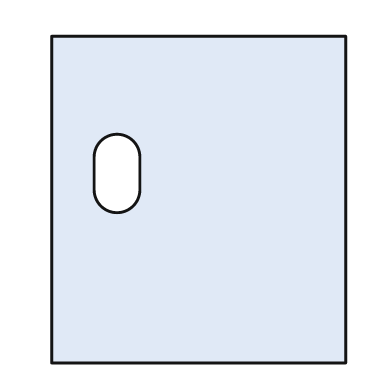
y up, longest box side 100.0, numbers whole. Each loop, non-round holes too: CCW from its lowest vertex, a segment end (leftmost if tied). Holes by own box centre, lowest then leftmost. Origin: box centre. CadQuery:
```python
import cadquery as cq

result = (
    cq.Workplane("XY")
    .moveTo(-45.0, -50.0)
    .lineTo(45.0, -50.0)
    .lineTo(45.0, 50.0)
    .lineTo(-45.0, 50.0)
    .close()
    .moveTo(-32.0, 3.0)
    .threePointArc((-25.0, -4.0), (-18.0, 3.0))
    .lineTo(-18.0, 13.0)
    .threePointArc((-25.0, 20.0), (-32.0, 13.0))
    .close()
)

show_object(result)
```